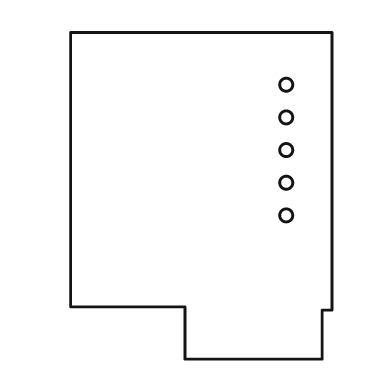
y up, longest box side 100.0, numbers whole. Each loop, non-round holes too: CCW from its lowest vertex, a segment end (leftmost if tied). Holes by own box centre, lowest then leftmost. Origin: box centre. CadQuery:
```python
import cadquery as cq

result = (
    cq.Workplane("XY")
    .moveTo(-5.0, -50.0)
    .lineTo(37.0, -50.0)
    .lineTo(37.0, -35.0)
    .lineTo(40.0, -35.0)
    .lineTo(40.0, 50.0)
    .lineTo(-40.0, 50.0)
    .lineTo(-40.0, -34.0)
    .lineTo(-5.0, -34.0)
    .close()
    .moveTo(26.0, -6.0)
    .circle(2.0)
    .moveTo(26.0, 4.0)
    .circle(2.0)
    .moveTo(26.0, 14.0)
    .circle(2.0)
    .moveTo(26.0, 24.0)
    .circle(2.0)
    .moveTo(26.0, 34.0)
    .circle(2.0)
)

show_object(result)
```